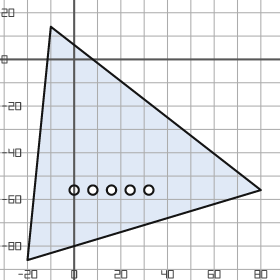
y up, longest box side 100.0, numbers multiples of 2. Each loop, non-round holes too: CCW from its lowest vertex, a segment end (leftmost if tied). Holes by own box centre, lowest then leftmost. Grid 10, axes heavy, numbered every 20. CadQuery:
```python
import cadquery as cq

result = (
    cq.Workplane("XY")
    .moveTo(-20.0, -86.0)
    .lineTo(80.0, -56.0)
    .lineTo(-10.0, 14.0)
    .close()
    .moveTo(0.0, -56.0)
    .circle(2.0)
    .moveTo(8.0, -56.0)
    .circle(2.0)
    .moveTo(16.0, -56.0)
    .circle(2.0)
    .moveTo(24.0, -56.0)
    .circle(2.0)
    .moveTo(32.0, -56.0)
    .circle(2.0)
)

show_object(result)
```